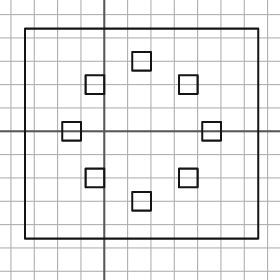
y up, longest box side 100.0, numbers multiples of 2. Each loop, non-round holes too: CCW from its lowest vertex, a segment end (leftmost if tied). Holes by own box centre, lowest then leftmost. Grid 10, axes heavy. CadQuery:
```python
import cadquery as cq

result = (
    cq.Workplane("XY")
    .moveTo(-34.0, -46.0)
    .lineTo(66.0, -46.0)
    .lineTo(66.0, 44.0)
    .lineTo(-34.0, 44.0)
    .close()
    .moveTo(12.0, -34.0)
    .lineTo(20.0, -34.0)
    .lineTo(20.0, -26.0)
    .lineTo(12.0, -26.0)
    .close()
    .moveTo(-8.0, -24.0)
    .lineTo(0.0, -24.0)
    .lineTo(0.0, -16.0)
    .lineTo(-8.0, -16.0)
    .close()
    .moveTo(32.0, -24.0)
    .lineTo(40.0, -24.0)
    .lineTo(40.0, -16.0)
    .lineTo(32.0, -16.0)
    .close()
    .moveTo(-18.0, -4.0)
    .lineTo(-10.0, -4.0)
    .lineTo(-10.0, 4.0)
    .lineTo(-18.0, 4.0)
    .close()
    .moveTo(42.0, -4.0)
    .lineTo(50.0, -4.0)
    .lineTo(50.0, 4.0)
    .lineTo(42.0, 4.0)
    .close()
    .moveTo(-8.0, 16.0)
    .lineTo(0.0, 16.0)
    .lineTo(0.0, 24.0)
    .lineTo(-8.0, 24.0)
    .close()
    .moveTo(32.0, 16.0)
    .lineTo(40.0, 16.0)
    .lineTo(40.0, 24.0)
    .lineTo(32.0, 24.0)
    .close()
    .moveTo(12.0, 26.0)
    .lineTo(20.0, 26.0)
    .lineTo(20.0, 34.0)
    .lineTo(12.0, 34.0)
    .close()
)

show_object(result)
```